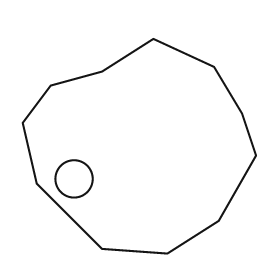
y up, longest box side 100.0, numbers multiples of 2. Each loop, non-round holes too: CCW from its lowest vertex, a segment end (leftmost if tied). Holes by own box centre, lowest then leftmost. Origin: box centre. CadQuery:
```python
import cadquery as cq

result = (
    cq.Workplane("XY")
    .moveTo(12.0, -46.0)
    .lineTo(34.0, -32.0)
    .lineTo(50.0, -4.0)
    .lineTo(44.0, 14.0)
    .lineTo(32.0, 34.0)
    .lineTo(6.0, 46.0)
    .lineTo(-16.0, 32.0)
    .lineTo(-38.0, 26.0)
    .lineTo(-50.0, 10.0)
    .lineTo(-44.0, -16.0)
    .lineTo(-16.0, -44.0)
    .close()
    .moveTo(-28.0, -14.0)
    .circle(8.0)
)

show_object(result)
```